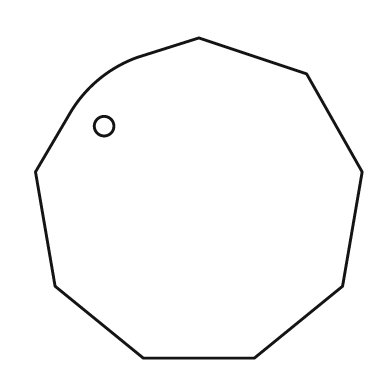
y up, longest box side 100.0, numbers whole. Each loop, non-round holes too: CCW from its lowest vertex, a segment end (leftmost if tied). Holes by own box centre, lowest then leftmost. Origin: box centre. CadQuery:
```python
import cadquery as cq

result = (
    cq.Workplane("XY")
    .moveTo(-17.0, -49.0)
    .lineTo(17.0, -49.0)
    .lineTo(44.0, -27.0)
    .lineTo(50.0, 8.0)
    .lineTo(33.0, 38.0)
    .lineTo(0.0, 49.0)
    .lineTo(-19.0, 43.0)
    .threePointArc((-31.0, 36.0), (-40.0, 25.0))
    .lineTo(-50.0, 8.0)
    .lineTo(-44.0, -27.0)
    .close()
    .moveTo(-29.0, 22.0)
    .circle(3.0)
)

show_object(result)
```